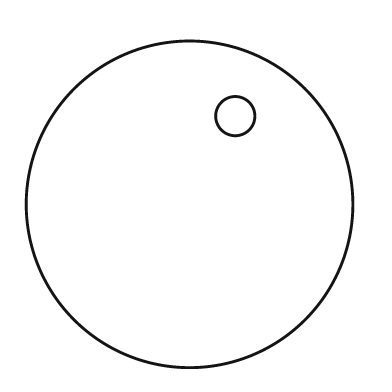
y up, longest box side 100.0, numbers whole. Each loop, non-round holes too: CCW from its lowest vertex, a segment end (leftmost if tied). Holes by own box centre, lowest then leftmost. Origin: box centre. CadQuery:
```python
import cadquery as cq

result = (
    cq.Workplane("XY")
    .moveTo(0.0, 0.0)
    .circle(50.0)
    .moveTo(14.0, 27.0)
    .circle(6.0)
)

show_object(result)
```